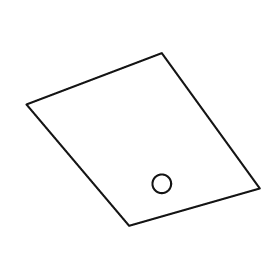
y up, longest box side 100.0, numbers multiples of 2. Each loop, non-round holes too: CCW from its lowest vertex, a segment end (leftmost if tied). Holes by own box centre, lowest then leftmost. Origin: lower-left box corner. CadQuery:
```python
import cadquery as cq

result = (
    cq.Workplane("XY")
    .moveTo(44.0, 0.0)
    .lineTo(100.0, 16.0)
    .lineTo(58.0, 74.0)
    .lineTo(0.0, 52.0)
    .close()
    .moveTo(58.0, 18.0)
    .circle(4.0)
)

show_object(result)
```